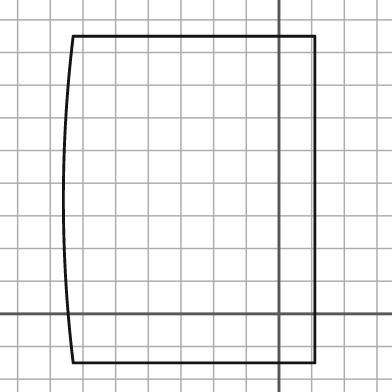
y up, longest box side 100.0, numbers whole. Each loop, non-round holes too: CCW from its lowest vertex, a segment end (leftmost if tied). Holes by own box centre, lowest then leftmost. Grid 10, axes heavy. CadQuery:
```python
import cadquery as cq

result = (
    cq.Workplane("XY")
    .moveTo(-63.0, -15.0)
    .lineTo(11.0, -15.0)
    .lineTo(11.0, 85.0)
    .lineTo(-63.0, 85.0)
    .threePointArc((-66.0, 35.0), (-63.0, -15.0))
    .close()
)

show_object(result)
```